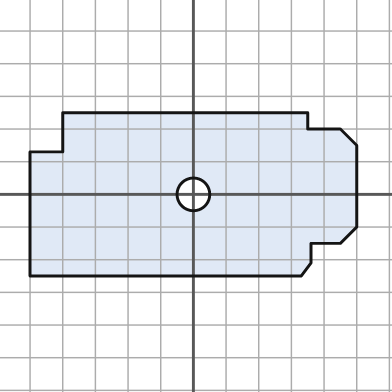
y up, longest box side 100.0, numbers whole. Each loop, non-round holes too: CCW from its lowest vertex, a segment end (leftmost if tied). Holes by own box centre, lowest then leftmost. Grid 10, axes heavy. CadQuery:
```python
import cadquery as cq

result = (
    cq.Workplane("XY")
    .moveTo(-50.0, -25.0)
    .lineTo(33.0, -25.0)
    .lineTo(36.0, -21.0)
    .lineTo(36.0, -15.0)
    .lineTo(45.0, -15.0)
    .lineTo(50.0, -10.0)
    .lineTo(50.0, 15.0)
    .lineTo(45.0, 20.0)
    .lineTo(35.0, 20.0)
    .lineTo(35.0, 25.0)
    .lineTo(-40.0, 25.0)
    .lineTo(-40.0, 13.0)
    .lineTo(-50.0, 13.0)
    .close()
    .moveTo(0.0, 0.0)
    .circle(5.0)
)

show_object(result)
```